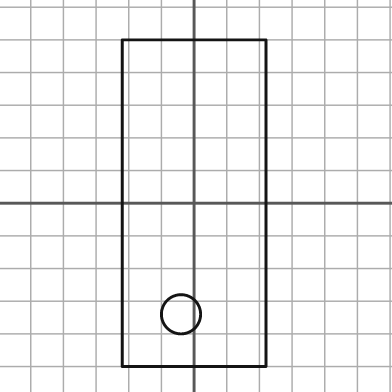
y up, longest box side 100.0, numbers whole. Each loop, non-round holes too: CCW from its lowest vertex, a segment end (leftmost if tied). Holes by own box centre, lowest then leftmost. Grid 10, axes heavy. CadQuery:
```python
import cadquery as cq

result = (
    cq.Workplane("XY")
    .moveTo(-22.0, -50.0)
    .lineTo(22.0, -50.0)
    .lineTo(22.0, 50.0)
    .lineTo(-22.0, 50.0)
    .close()
    .moveTo(-4.0, -34.0)
    .circle(6.0)
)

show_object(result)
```